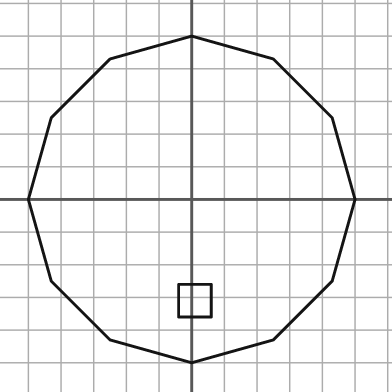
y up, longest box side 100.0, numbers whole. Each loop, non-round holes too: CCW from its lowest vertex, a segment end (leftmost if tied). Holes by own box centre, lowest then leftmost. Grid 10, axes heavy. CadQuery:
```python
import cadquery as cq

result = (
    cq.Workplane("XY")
    .moveTo(0.0, -50.0)
    .lineTo(25.0, -43.0)
    .lineTo(43.0, -25.0)
    .lineTo(50.0, 0.0)
    .lineTo(43.0, 25.0)
    .lineTo(25.0, 43.0)
    .lineTo(0.0, 50.0)
    .lineTo(-25.0, 43.0)
    .lineTo(-43.0, 25.0)
    .lineTo(-50.0, 0.0)
    .lineTo(-43.0, -25.0)
    .lineTo(-25.0, -43.0)
    .close()
    .moveTo(-4.0, -36.0)
    .lineTo(6.0, -36.0)
    .lineTo(6.0, -26.0)
    .lineTo(-4.0, -26.0)
    .close()
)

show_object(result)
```